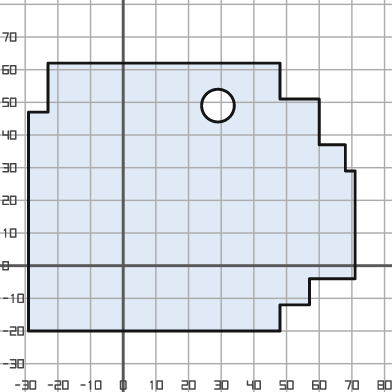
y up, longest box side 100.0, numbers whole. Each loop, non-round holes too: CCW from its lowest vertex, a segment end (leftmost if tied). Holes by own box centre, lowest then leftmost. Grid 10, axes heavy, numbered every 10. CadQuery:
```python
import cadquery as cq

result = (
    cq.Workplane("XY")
    .moveTo(-29.0, -20.0)
    .lineTo(48.0, -20.0)
    .lineTo(48.0, -12.0)
    .lineTo(57.0, -12.0)
    .lineTo(57.0, -4.0)
    .lineTo(71.0, -4.0)
    .lineTo(71.0, 29.0)
    .lineTo(68.0, 29.0)
    .lineTo(68.0, 37.0)
    .lineTo(60.0, 37.0)
    .lineTo(60.0, 51.0)
    .lineTo(48.0, 51.0)
    .lineTo(48.0, 62.0)
    .lineTo(-23.0, 62.0)
    .lineTo(-23.0, 47.0)
    .lineTo(-29.0, 47.0)
    .close()
    .moveTo(29.0, 49.0)
    .circle(5.0)
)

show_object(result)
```